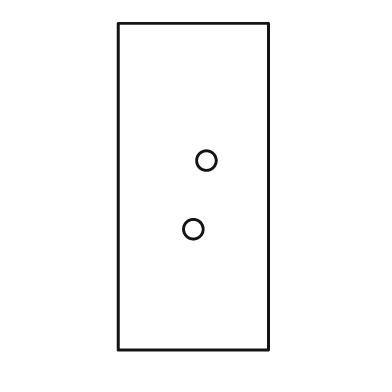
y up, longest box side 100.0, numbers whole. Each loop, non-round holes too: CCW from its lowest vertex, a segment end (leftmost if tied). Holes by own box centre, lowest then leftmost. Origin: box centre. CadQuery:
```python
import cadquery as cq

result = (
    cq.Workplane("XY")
    .moveTo(-23.0, -50.0)
    .lineTo(23.0, -50.0)
    .lineTo(23.0, 50.0)
    .lineTo(-23.0, 50.0)
    .close()
    .moveTo(0.0, -13.0)
    .circle(3.0)
    .moveTo(4.0, 8.0)
    .circle(3.0)
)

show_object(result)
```